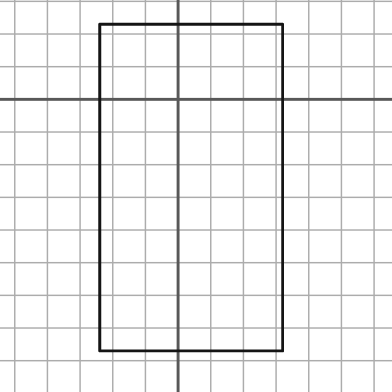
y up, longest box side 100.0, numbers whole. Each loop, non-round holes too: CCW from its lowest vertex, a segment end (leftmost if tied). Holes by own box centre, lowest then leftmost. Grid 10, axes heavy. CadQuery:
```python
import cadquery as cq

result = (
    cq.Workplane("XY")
    .moveTo(-24.0, -77.0)
    .lineTo(32.0, -77.0)
    .lineTo(32.0, 23.0)
    .lineTo(-24.0, 23.0)
    .close()
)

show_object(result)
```